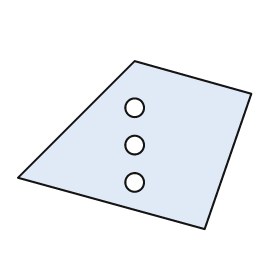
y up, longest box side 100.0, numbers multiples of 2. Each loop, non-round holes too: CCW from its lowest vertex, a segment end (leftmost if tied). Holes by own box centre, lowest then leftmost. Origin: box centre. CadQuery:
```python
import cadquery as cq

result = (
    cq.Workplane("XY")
    .moveTo(30.0, -36.0)
    .lineTo(50.0, 22.0)
    .lineTo(0.0, 36.0)
    .lineTo(-50.0, -14.0)
    .close()
    .moveTo(0.0, -16.0)
    .circle(4.0)
    .moveTo(0.0, 0.0)
    .circle(4.0)
    .moveTo(0.0, 16.0)
    .circle(4.0)
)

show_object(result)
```